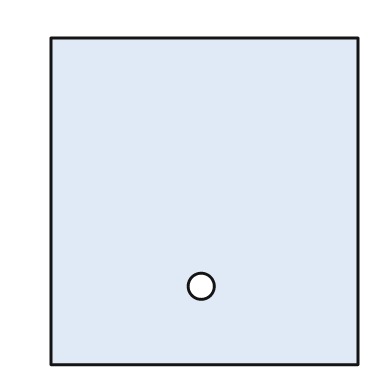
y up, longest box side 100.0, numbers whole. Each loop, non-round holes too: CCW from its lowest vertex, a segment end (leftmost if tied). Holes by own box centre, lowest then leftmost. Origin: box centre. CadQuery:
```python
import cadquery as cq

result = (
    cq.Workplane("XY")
    .moveTo(-47.0, -50.0)
    .lineTo(47.0, -50.0)
    .lineTo(47.0, 50.0)
    .lineTo(-47.0, 50.0)
    .close()
    .moveTo(-1.0, -26.0)
    .circle(4.0)
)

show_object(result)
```